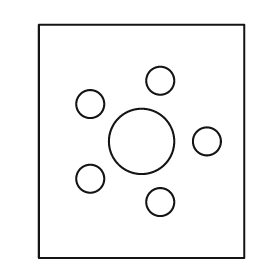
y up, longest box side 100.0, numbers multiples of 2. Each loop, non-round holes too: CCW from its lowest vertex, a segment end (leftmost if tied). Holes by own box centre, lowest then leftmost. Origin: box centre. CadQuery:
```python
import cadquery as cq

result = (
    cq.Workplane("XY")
    .moveTo(-44.0, -50.0)
    .lineTo(44.0, -50.0)
    .lineTo(44.0, 50.0)
    .lineTo(-44.0, 50.0)
    .close()
    .moveTo(8.0, -26.0)
    .circle(6.0)
    .moveTo(-22.0, -16.0)
    .circle(6.0)
    .moveTo(0.0, 0.0)
    .circle(14.0)
    .moveTo(28.0, 0.0)
    .circle(6.0)
    .moveTo(-22.0, 16.0)
    .circle(6.0)
    .moveTo(8.0, 26.0)
    .circle(6.0)
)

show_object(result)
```